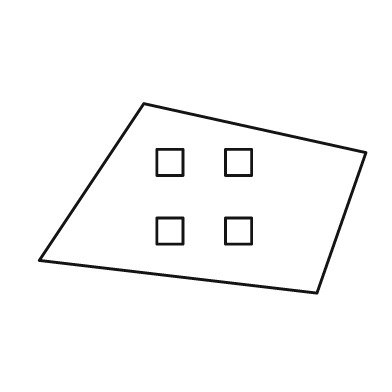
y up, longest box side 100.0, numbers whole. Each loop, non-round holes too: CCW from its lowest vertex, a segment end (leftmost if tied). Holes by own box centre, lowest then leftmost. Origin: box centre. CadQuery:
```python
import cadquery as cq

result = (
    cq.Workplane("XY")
    .moveTo(35.0, -29.0)
    .lineTo(50.0, 14.0)
    .lineTo(-18.0, 29.0)
    .lineTo(-50.0, -19.0)
    .close()
    .moveTo(-14.0, -14.0)
    .lineTo(-6.0, -14.0)
    .lineTo(-6.0, -6.0)
    .lineTo(-14.0, -6.0)
    .close()
    .moveTo(7.0, -14.0)
    .lineTo(15.0, -14.0)
    .lineTo(15.0, -6.0)
    .lineTo(7.0, -6.0)
    .close()
    .moveTo(-14.0, 7.0)
    .lineTo(-6.0, 7.0)
    .lineTo(-6.0, 15.0)
    .lineTo(-14.0, 15.0)
    .close()
    .moveTo(7.0, 7.0)
    .lineTo(15.0, 7.0)
    .lineTo(15.0, 15.0)
    .lineTo(7.0, 15.0)
    .close()
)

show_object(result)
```